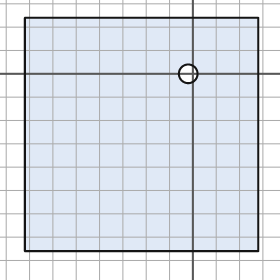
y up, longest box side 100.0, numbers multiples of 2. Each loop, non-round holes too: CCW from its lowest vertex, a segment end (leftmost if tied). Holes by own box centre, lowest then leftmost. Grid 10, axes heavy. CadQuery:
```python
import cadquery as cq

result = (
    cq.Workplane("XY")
    .moveTo(-72.0, -76.0)
    .lineTo(28.0, -76.0)
    .lineTo(28.0, 24.0)
    .lineTo(-72.0, 24.0)
    .close()
    .moveTo(-2.0, 0.0)
    .circle(4.0)
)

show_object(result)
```